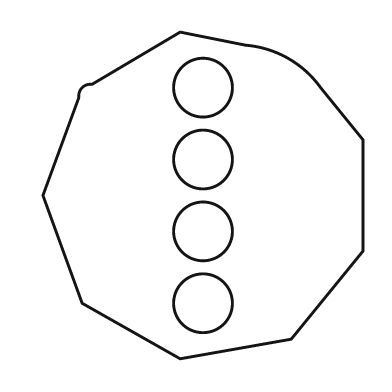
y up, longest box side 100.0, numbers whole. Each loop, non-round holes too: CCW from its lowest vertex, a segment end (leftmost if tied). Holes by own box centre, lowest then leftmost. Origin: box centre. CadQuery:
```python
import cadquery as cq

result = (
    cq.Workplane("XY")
    .moveTo(-7.0, -50.0)
    .lineTo(27.0, -44.0)
    .lineTo(49.0, -17.0)
    .lineTo(49.0, 17.0)
    .lineTo(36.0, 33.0)
    .threePointArc((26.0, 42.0), (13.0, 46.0))
    .lineTo(-7.0, 50.0)
    .lineTo(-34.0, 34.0)
    .threePointArc((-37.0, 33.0), (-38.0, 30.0))
    .lineTo(-49.0, 0.0)
    .lineTo(-37.0, -33.0)
    .close()
    .moveTo(0.0, -33.0)
    .circle(9.0)
    .moveTo(0.0, -11.0)
    .circle(9.0)
    .moveTo(0.0, 11.0)
    .circle(9.0)
    .moveTo(0.0, 33.0)
    .circle(9.0)
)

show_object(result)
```